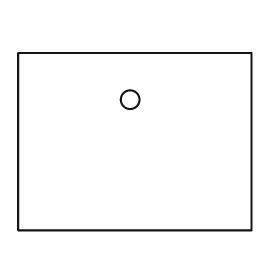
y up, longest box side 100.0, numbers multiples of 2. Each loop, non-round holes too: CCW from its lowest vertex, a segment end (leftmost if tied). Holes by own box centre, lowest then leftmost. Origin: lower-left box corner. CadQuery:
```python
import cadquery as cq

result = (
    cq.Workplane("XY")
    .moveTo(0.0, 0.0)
    .lineTo(100.0, 0.0)
    .lineTo(100.0, 76.0)
    .lineTo(0.0, 76.0)
    .close()
    .moveTo(48.0, 56.0)
    .circle(4.0)
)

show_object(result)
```